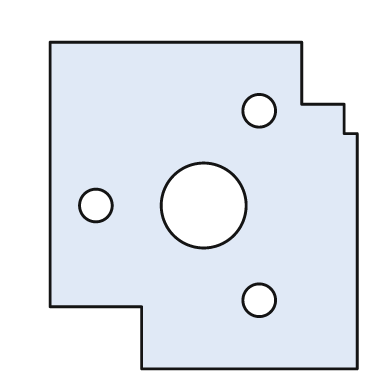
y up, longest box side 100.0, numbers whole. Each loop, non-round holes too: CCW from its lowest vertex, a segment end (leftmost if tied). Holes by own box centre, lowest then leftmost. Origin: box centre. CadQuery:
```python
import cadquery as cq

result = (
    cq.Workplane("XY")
    .moveTo(-19.0, -50.0)
    .lineTo(47.0, -50.0)
    .lineTo(47.0, 22.0)
    .lineTo(43.0, 22.0)
    .lineTo(43.0, 31.0)
    .lineTo(30.0, 31.0)
    .lineTo(30.0, 50.0)
    .lineTo(-47.0, 50.0)
    .lineTo(-47.0, -31.0)
    .lineTo(-19.0, -31.0)
    .close()
    .moveTo(17.0, -29.0)
    .circle(5.0)
    .moveTo(-33.0, 0.0)
    .circle(5.0)
    .moveTo(0.0, 0.0)
    .circle(13.0)
    .moveTo(17.0, 29.0)
    .circle(5.0)
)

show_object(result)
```